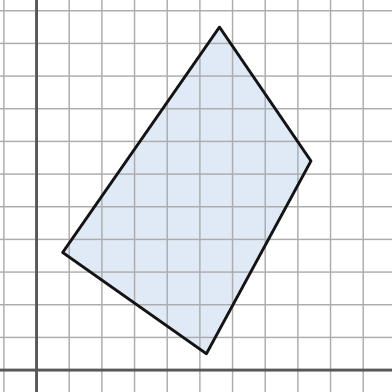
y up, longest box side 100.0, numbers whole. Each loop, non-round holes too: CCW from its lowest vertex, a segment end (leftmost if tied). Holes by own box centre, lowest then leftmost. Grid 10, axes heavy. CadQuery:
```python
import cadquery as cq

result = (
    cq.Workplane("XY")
    .moveTo(52.0, 5.0)
    .lineTo(84.0, 64.0)
    .lineTo(56.0, 105.0)
    .lineTo(8.0, 36.0)
    .close()
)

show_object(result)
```